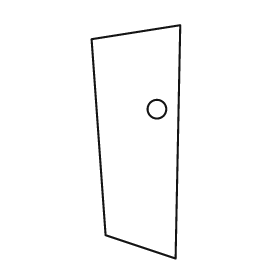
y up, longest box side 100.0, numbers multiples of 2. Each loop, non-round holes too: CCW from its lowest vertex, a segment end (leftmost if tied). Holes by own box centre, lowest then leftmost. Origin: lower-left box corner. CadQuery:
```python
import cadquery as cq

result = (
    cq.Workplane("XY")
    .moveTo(36.0, 0.0)
    .lineTo(38.0, 100.0)
    .lineTo(0.0, 94.0)
    .lineTo(6.0, 10.0)
    .close()
    .moveTo(28.0, 64.0)
    .circle(4.0)
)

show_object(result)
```